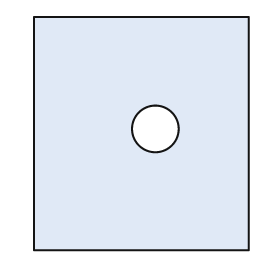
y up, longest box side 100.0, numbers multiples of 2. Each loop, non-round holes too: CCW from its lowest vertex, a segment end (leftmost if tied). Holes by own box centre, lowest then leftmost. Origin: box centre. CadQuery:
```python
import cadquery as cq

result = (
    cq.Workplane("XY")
    .moveTo(-46.0, -50.0)
    .lineTo(46.0, -50.0)
    .lineTo(46.0, 50.0)
    .lineTo(-46.0, 50.0)
    .close()
    .moveTo(6.0, 2.0)
    .circle(10.0)
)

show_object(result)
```